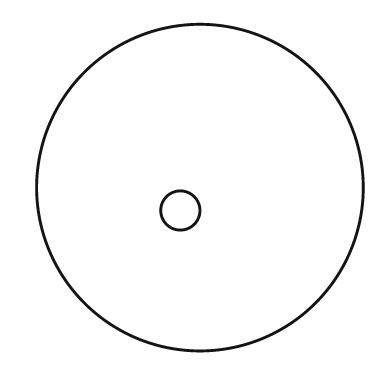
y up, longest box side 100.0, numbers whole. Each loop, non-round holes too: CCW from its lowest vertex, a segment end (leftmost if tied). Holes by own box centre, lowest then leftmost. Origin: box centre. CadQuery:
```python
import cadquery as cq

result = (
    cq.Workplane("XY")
    .moveTo(0.0, 0.0)
    .circle(50.0)
    .moveTo(-6.0, -7.0)
    .circle(6.0)
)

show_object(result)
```